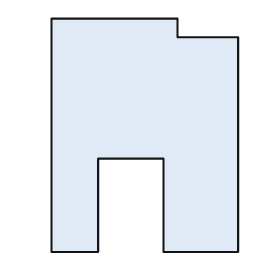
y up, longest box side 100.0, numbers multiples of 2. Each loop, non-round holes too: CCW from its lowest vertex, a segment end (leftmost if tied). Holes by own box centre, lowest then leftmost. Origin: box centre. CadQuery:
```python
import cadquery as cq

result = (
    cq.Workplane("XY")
    .moveTo(-40.0, -50.0)
    .lineTo(-20.0, -50.0)
    .lineTo(-20.0, -10.0)
    .lineTo(8.0, -10.0)
    .lineTo(8.0, -50.0)
    .lineTo(40.0, -50.0)
    .lineTo(40.0, 42.0)
    .lineTo(14.0, 42.0)
    .lineTo(14.0, 50.0)
    .lineTo(-40.0, 50.0)
    .close()
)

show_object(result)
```